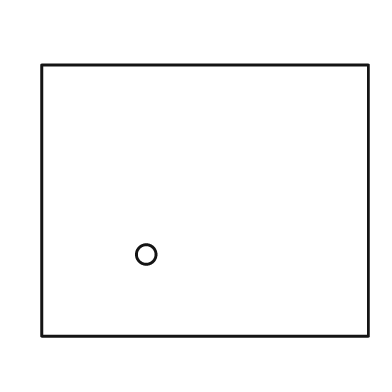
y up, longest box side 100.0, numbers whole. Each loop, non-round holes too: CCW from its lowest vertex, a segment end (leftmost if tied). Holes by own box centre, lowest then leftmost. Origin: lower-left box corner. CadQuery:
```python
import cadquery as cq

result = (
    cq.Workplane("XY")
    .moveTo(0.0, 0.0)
    .lineTo(100.0, 0.0)
    .lineTo(100.0, 83.0)
    .lineTo(0.0, 83.0)
    .close()
    .moveTo(32.0, 25.0)
    .circle(3.0)
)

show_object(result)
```